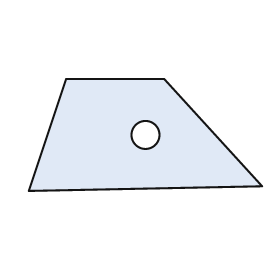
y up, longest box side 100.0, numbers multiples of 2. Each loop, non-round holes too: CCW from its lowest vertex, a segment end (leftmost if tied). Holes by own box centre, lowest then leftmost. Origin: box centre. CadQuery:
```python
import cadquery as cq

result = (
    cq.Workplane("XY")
    .moveTo(-50.0, -24.0)
    .lineTo(50.0, -22.0)
    .lineTo(8.0, 24.0)
    .lineTo(-34.0, 24.0)
    .close()
    .moveTo(0.0, 0.0)
    .circle(6.0)
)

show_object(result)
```